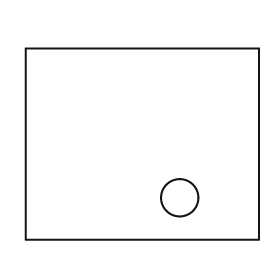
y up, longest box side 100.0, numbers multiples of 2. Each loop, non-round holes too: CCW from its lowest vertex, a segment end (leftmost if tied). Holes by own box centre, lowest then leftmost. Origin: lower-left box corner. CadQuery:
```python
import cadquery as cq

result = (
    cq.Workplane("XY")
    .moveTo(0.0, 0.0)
    .lineTo(100.0, 0.0)
    .lineTo(100.0, 82.0)
    .lineTo(0.0, 82.0)
    .close()
    .moveTo(66.0, 18.0)
    .circle(8.0)
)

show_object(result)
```